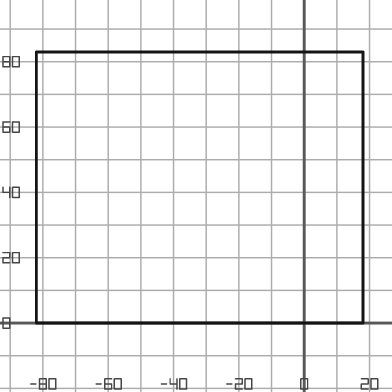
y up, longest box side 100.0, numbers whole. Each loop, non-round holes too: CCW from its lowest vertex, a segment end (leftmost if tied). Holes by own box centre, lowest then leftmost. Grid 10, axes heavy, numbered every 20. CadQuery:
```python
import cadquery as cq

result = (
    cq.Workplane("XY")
    .moveTo(-82.0, 0.0)
    .lineTo(18.0, 0.0)
    .lineTo(18.0, 83.0)
    .lineTo(-82.0, 83.0)
    .close()
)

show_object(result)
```